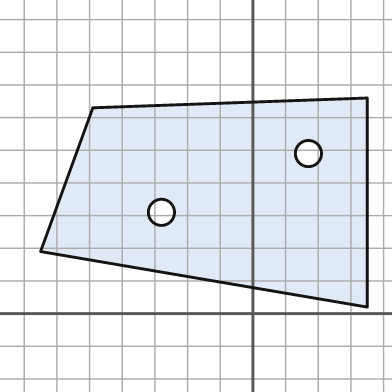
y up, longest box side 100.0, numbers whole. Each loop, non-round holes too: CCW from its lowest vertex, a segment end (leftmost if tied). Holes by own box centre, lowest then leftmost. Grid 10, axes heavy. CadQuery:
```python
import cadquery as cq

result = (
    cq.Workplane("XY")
    .moveTo(35.0, 2.0)
    .lineTo(35.0, 66.0)
    .lineTo(-49.0, 63.0)
    .lineTo(-65.0, 19.0)
    .close()
    .moveTo(-28.0, 31.0)
    .circle(4.0)
    .moveTo(17.0, 49.0)
    .circle(4.0)
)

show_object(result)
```